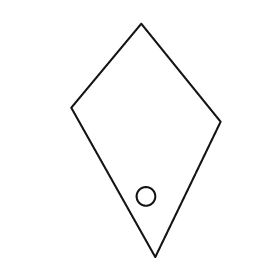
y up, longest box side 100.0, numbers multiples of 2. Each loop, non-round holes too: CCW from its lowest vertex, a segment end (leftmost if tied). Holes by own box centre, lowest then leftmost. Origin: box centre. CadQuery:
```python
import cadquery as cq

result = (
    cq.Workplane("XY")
    .moveTo(4.0, -50.0)
    .lineTo(32.0, 8.0)
    .lineTo(-2.0, 50.0)
    .lineTo(-32.0, 14.0)
    .close()
    .moveTo(0.0, -24.0)
    .circle(4.0)
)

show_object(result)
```